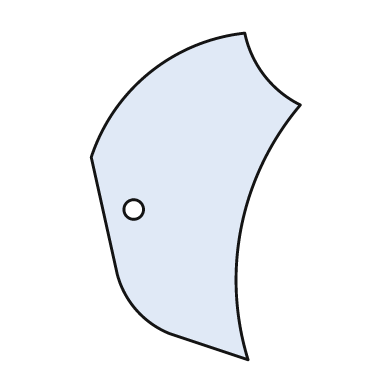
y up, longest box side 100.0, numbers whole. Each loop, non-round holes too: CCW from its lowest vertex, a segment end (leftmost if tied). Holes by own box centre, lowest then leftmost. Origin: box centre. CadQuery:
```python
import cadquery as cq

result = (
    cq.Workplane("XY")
    .moveTo(16.0, -50.0)
    .threePointArc((14.0, -9.0), (32.0, 28.0))
    .threePointArc((21.0, 37.0), (15.0, 50.0))
    .threePointArc((-14.0, 38.0), (-32.0, 12.0))
    .lineTo(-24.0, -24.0)
    .threePointArc((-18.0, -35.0), (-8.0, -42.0))
    .close()
    .moveTo(-19.0, -4.0)
    .circle(3.0)
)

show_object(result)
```